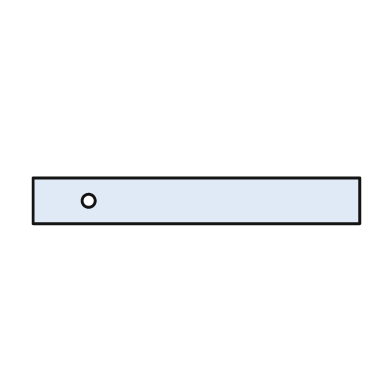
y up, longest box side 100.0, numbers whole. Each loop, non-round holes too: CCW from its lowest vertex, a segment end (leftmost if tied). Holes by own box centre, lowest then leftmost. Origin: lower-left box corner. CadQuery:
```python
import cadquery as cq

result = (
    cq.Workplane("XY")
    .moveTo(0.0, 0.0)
    .lineTo(100.0, 0.0)
    .lineTo(100.0, 14.0)
    .lineTo(0.0, 14.0)
    .close()
    .moveTo(17.0, 7.0)
    .circle(2.0)
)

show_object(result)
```